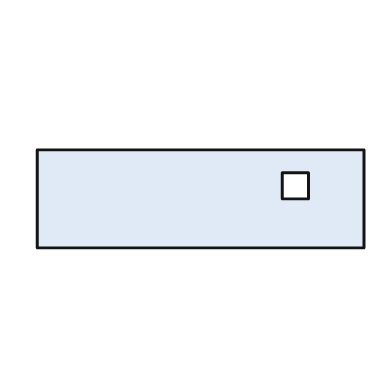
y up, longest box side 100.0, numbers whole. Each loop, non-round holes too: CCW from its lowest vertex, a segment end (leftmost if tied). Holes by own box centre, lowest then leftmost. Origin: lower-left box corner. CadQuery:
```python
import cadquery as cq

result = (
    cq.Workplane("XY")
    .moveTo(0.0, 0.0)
    .lineTo(100.0, 0.0)
    .lineTo(100.0, 30.0)
    .lineTo(0.0, 30.0)
    .close()
    .moveTo(75.0, 15.0)
    .lineTo(83.0, 15.0)
    .lineTo(83.0, 23.0)
    .lineTo(75.0, 23.0)
    .close()
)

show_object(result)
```